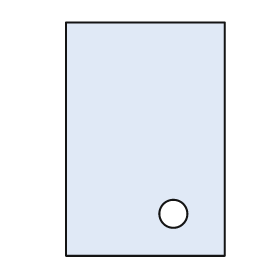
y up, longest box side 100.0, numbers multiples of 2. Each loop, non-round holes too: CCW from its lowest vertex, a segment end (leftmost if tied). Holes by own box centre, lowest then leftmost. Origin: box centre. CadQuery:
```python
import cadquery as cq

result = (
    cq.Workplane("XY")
    .moveTo(-34.0, -50.0)
    .lineTo(34.0, -50.0)
    .lineTo(34.0, 50.0)
    .lineTo(-34.0, 50.0)
    .close()
    .moveTo(12.0, -32.0)
    .circle(6.0)
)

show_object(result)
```